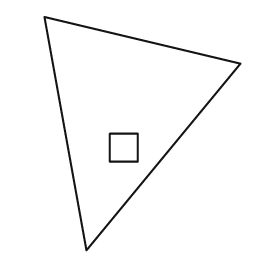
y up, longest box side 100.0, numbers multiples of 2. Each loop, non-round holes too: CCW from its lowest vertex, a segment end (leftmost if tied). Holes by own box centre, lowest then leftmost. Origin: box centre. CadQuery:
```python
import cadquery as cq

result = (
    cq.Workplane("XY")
    .moveTo(-24.0, -50.0)
    .lineTo(42.0, 30.0)
    .lineTo(-42.0, 50.0)
    .close()
    .moveTo(-14.0, -12.0)
    .lineTo(-2.0, -12.0)
    .lineTo(-2.0, 0.0)
    .lineTo(-14.0, 0.0)
    .close()
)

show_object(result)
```